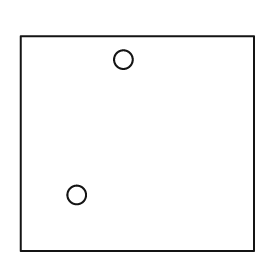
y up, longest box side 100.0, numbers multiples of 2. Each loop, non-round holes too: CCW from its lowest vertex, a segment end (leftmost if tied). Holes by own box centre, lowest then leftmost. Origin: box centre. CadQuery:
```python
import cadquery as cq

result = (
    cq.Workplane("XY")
    .moveTo(-50.0, -46.0)
    .lineTo(50.0, -46.0)
    .lineTo(50.0, 46.0)
    .lineTo(-50.0, 46.0)
    .close()
    .moveTo(-26.0, -22.0)
    .circle(4.0)
    .moveTo(-6.0, 36.0)
    .circle(4.0)
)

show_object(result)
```